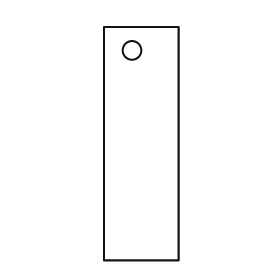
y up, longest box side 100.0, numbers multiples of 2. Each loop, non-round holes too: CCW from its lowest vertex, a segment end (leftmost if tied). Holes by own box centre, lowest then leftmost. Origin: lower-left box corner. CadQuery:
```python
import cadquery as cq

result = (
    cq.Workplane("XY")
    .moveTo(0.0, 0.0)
    .lineTo(32.0, 0.0)
    .lineTo(32.0, 100.0)
    .lineTo(0.0, 100.0)
    .close()
    .moveTo(12.0, 90.0)
    .circle(4.0)
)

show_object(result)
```